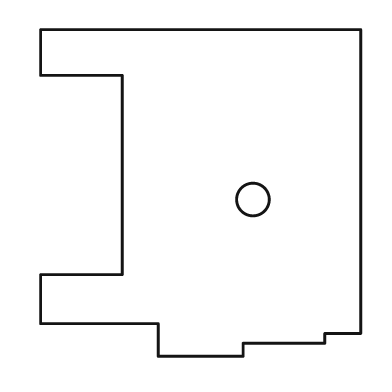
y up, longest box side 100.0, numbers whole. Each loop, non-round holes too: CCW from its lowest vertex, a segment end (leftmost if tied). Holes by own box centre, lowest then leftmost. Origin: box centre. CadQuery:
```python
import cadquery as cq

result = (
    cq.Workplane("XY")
    .moveTo(-13.0, -50.0)
    .lineTo(13.0, -50.0)
    .lineTo(13.0, -46.0)
    .lineTo(38.0, -46.0)
    .lineTo(38.0, -43.0)
    .lineTo(49.0, -43.0)
    .lineTo(49.0, 50.0)
    .lineTo(-49.0, 50.0)
    .lineTo(-49.0, 36.0)
    .lineTo(-24.0, 36.0)
    .lineTo(-24.0, -25.0)
    .lineTo(-49.0, -25.0)
    .lineTo(-49.0, -40.0)
    .lineTo(-13.0, -40.0)
    .close()
    .moveTo(16.0, -2.0)
    .circle(5.0)
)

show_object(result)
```